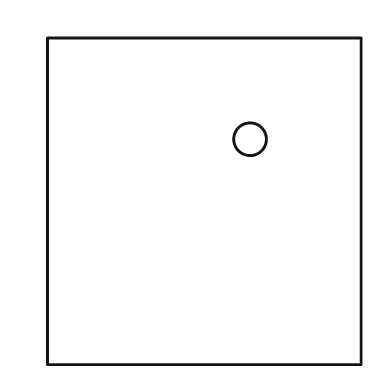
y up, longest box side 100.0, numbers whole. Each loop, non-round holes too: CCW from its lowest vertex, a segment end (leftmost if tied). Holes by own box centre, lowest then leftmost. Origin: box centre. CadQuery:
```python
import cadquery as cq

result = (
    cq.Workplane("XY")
    .moveTo(-48.0, -50.0)
    .lineTo(48.0, -50.0)
    .lineTo(48.0, 50.0)
    .lineTo(-48.0, 50.0)
    .close()
    .moveTo(14.0, 19.0)
    .circle(5.0)
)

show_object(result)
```